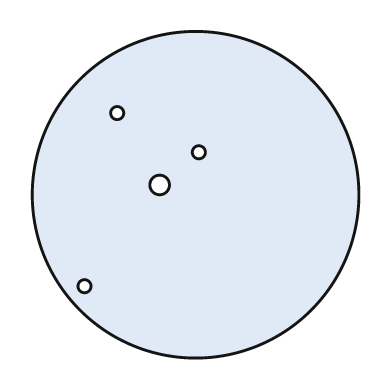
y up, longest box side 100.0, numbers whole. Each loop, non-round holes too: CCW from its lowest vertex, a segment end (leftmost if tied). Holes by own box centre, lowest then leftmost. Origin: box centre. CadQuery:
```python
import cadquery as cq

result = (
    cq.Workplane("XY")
    .moveTo(0.0, 0.0)
    .circle(50.0)
    .moveTo(-34.0, -28.0)
    .circle(2.0)
    .moveTo(-11.0, 3.0)
    .circle(3.0)
    .moveTo(1.0, 13.0)
    .circle(2.0)
    .moveTo(-24.0, 25.0)
    .circle(2.0)
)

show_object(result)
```